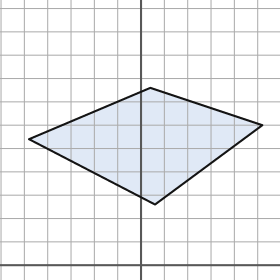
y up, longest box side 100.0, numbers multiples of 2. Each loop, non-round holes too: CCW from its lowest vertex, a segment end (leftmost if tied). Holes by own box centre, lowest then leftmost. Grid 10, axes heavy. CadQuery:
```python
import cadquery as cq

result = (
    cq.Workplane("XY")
    .moveTo(6.0, 26.0)
    .lineTo(52.0, 60.0)
    .lineTo(4.0, 76.0)
    .lineTo(-48.0, 54.0)
    .close()
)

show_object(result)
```